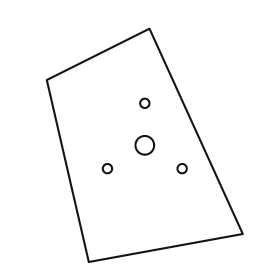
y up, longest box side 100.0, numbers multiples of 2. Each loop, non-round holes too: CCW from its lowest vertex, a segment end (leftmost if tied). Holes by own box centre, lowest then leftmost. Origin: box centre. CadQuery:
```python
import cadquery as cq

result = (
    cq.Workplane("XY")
    .moveTo(-24.0, -50.0)
    .lineTo(42.0, -38.0)
    .lineTo(2.0, 50.0)
    .lineTo(-42.0, 28.0)
    .close()
    .moveTo(-16.0, -10.0)
    .circle(2.0)
    .moveTo(16.0, -10.0)
    .circle(2.0)
    .moveTo(0.0, 0.0)
    .circle(4.0)
    .moveTo(0.0, 18.0)
    .circle(2.0)
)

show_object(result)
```